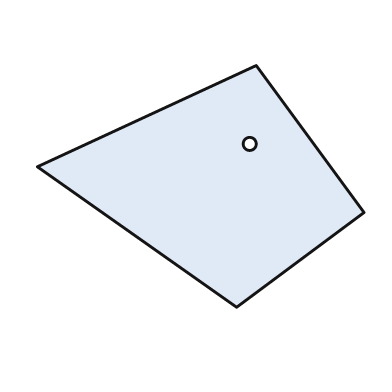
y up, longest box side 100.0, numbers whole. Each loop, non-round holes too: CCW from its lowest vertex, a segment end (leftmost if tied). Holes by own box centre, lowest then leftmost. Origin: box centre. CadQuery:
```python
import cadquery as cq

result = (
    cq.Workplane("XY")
    .moveTo(11.0, -37.0)
    .lineTo(50.0, -8.0)
    .lineTo(17.0, 37.0)
    .lineTo(-50.0, 6.0)
    .close()
    .moveTo(15.0, 13.0)
    .circle(2.0)
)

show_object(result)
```